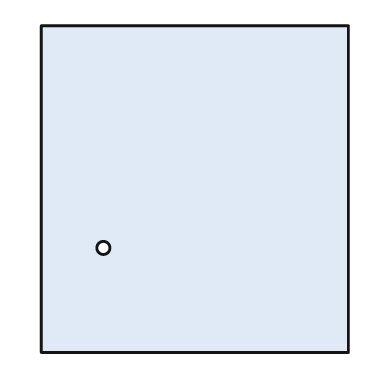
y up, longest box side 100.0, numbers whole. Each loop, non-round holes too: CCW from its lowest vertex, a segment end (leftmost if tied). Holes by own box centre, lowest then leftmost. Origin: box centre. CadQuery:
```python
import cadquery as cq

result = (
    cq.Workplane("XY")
    .moveTo(-47.0, -50.0)
    .lineTo(47.0, -50.0)
    .lineTo(47.0, 50.0)
    .lineTo(-47.0, 50.0)
    .close()
    .moveTo(-28.0, -18.0)
    .circle(2.0)
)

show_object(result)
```